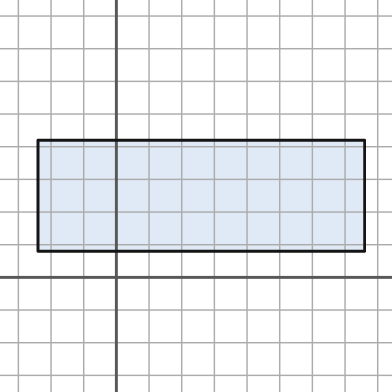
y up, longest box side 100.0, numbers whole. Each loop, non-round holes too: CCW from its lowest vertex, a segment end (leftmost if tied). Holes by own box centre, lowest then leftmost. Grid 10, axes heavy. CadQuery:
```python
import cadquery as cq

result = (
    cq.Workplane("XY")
    .moveTo(-24.0, 8.0)
    .lineTo(76.0, 8.0)
    .lineTo(76.0, 42.0)
    .lineTo(-24.0, 42.0)
    .close()
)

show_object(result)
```